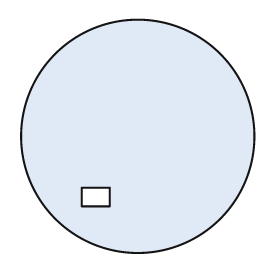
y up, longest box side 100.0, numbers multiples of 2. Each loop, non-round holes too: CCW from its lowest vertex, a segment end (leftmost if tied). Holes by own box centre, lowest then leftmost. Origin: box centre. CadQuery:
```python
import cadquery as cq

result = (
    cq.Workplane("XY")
    .moveTo(0.0, 0.0)
    .circle(50.0)
    .moveTo(-24.0, -30.0)
    .lineTo(-12.0, -30.0)
    .lineTo(-12.0, -22.0)
    .lineTo(-24.0, -22.0)
    .close()
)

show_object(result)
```